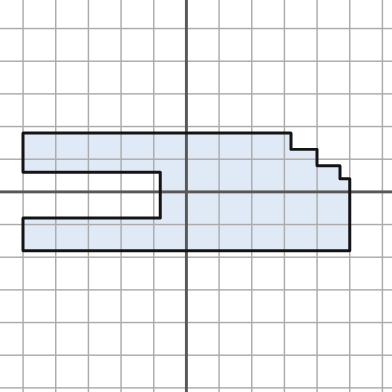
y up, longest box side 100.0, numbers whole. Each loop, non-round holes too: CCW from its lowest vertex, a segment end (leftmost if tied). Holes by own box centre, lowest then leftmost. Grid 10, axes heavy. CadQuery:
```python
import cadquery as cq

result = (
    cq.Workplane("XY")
    .moveTo(-50.0, -18.0)
    .lineTo(50.0, -18.0)
    .lineTo(50.0, 4.0)
    .lineTo(47.0, 4.0)
    .lineTo(47.0, 8.0)
    .lineTo(40.0, 8.0)
    .lineTo(40.0, 13.0)
    .lineTo(32.0, 13.0)
    .lineTo(32.0, 18.0)
    .lineTo(-50.0, 18.0)
    .lineTo(-50.0, 6.0)
    .lineTo(-8.0, 6.0)
    .lineTo(-8.0, -8.0)
    .lineTo(-50.0, -8.0)
    .close()
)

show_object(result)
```